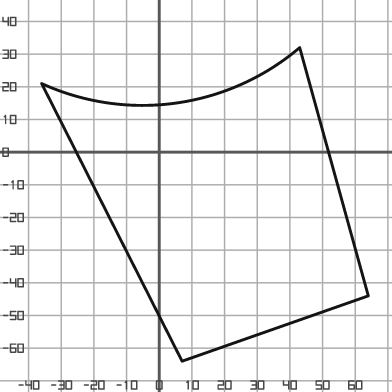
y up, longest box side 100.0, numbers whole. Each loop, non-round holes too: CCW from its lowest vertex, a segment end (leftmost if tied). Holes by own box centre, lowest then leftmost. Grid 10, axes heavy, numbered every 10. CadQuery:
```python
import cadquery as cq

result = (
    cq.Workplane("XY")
    .moveTo(7.0, -64.0)
    .lineTo(64.0, -44.0)
    .lineTo(43.0, 32.0)
    .threePointArc((5.0, 15.0), (-36.0, 21.0))
    .close()
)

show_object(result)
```